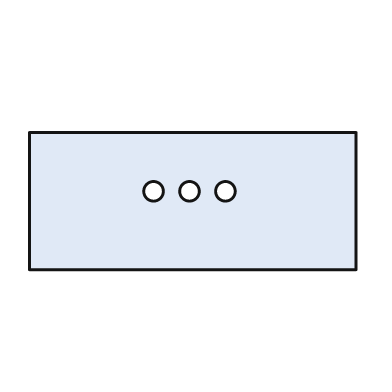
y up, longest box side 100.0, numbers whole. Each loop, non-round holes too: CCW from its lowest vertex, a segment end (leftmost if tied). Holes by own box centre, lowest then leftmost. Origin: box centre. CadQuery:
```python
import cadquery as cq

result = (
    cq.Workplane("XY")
    .moveTo(-50.0, -21.0)
    .lineTo(50.0, -21.0)
    .lineTo(50.0, 21.0)
    .lineTo(-50.0, 21.0)
    .close()
    .moveTo(-12.0, 3.0)
    .circle(3.0)
    .moveTo(-1.0, 3.0)
    .circle(3.0)
    .moveTo(10.0, 3.0)
    .circle(3.0)
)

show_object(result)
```